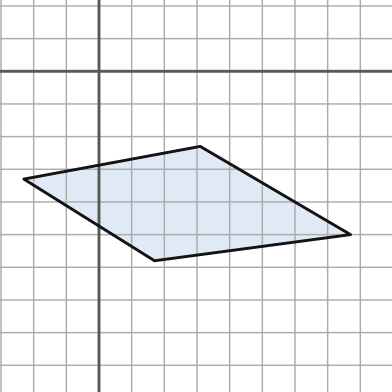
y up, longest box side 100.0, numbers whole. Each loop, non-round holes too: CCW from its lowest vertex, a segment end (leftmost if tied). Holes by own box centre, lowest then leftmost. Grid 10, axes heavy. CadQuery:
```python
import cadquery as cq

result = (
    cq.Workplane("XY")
    .moveTo(17.0, -58.0)
    .lineTo(77.0, -50.0)
    .lineTo(31.0, -23.0)
    .lineTo(-23.0, -33.0)
    .close()
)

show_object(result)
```